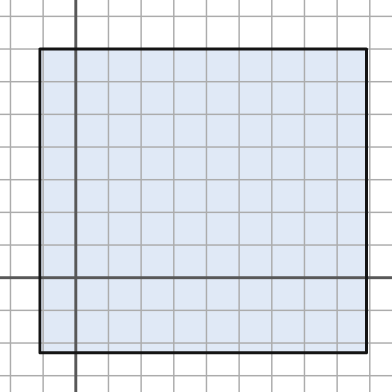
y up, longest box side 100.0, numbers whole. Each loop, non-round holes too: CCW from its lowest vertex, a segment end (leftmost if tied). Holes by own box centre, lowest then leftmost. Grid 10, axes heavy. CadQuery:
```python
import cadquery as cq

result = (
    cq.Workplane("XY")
    .moveTo(-11.0, -23.0)
    .lineTo(89.0, -23.0)
    .lineTo(89.0, 70.0)
    .lineTo(-11.0, 70.0)
    .close()
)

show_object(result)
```